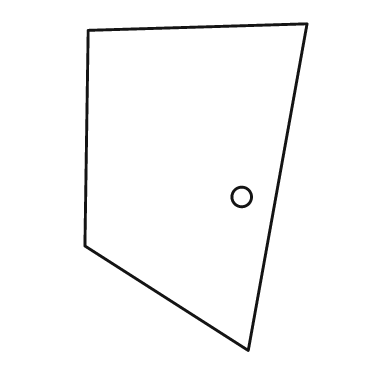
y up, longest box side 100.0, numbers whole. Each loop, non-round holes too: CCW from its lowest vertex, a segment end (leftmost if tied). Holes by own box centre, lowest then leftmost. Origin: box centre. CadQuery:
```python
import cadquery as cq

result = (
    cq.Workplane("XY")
    .moveTo(16.0, -50.0)
    .lineTo(34.0, 50.0)
    .lineTo(-33.0, 48.0)
    .lineTo(-34.0, -18.0)
    .close()
    .moveTo(14.0, -3.0)
    .circle(3.0)
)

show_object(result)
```